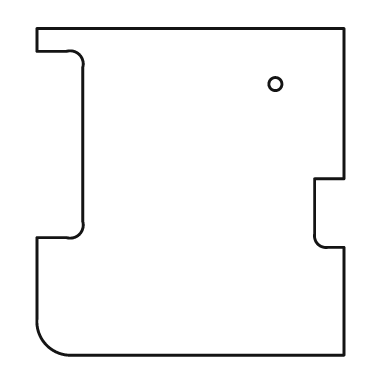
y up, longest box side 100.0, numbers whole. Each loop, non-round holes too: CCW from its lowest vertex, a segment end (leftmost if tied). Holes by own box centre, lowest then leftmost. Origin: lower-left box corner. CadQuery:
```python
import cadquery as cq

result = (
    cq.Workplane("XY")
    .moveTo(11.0, 0.0)
    .lineTo(94.0, 0.0)
    .lineTo(94.0, 33.0)
    .lineTo(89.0, 33.0)
    .threePointArc((86.0, 34.0), (85.0, 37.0))
    .lineTo(85.0, 54.0)
    .lineTo(94.0, 54.0)
    .lineTo(94.0, 100.0)
    .lineTo(0.0, 100.0)
    .lineTo(0.0, 93.0)
    .lineTo(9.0, 93.0)
    .threePointArc((13.0, 92.0), (14.0, 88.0))
    .lineTo(14.0, 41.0)
    .threePointArc((13.0, 37.0), (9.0, 36.0))
    .lineTo(0.0, 36.0)
    .lineTo(0.0, 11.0)
    .threePointArc((3.0, 3.0), (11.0, 0.0))
    .close()
    .moveTo(73.0, 83.0)
    .circle(2.0)
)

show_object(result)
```